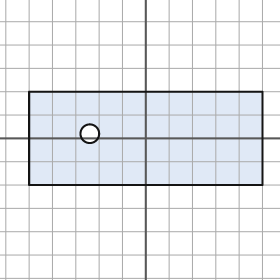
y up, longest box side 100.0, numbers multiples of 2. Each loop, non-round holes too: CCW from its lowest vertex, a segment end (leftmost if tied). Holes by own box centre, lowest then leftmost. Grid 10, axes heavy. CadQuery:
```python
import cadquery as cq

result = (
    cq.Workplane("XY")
    .moveTo(-50.0, -20.0)
    .lineTo(50.0, -20.0)
    .lineTo(50.0, 20.0)
    .lineTo(-50.0, 20.0)
    .close()
    .moveTo(-24.0, 2.0)
    .circle(4.0)
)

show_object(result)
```